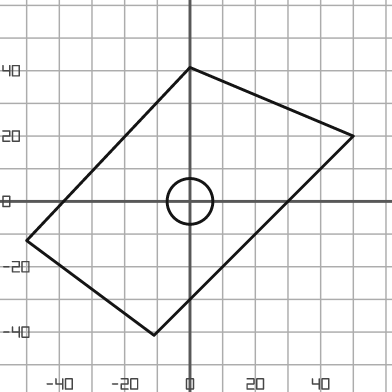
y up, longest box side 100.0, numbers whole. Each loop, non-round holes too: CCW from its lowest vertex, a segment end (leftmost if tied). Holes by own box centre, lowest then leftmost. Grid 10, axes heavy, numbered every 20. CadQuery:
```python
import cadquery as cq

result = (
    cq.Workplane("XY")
    .moveTo(-11.0, -41.0)
    .lineTo(50.0, 20.0)
    .lineTo(0.0, 41.0)
    .lineTo(-50.0, -12.0)
    .close()
    .moveTo(0.0, 0.0)
    .circle(7.0)
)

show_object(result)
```